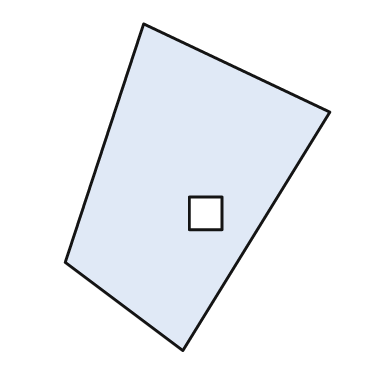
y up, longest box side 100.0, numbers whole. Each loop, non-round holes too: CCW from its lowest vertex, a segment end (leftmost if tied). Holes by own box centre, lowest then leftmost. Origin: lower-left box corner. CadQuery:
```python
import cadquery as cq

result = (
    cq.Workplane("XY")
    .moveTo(36.0, 0.0)
    .lineTo(81.0, 73.0)
    .lineTo(24.0, 100.0)
    .lineTo(0.0, 27.0)
    .close()
    .moveTo(38.0, 37.0)
    .lineTo(48.0, 37.0)
    .lineTo(48.0, 47.0)
    .lineTo(38.0, 47.0)
    .close()
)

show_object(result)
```